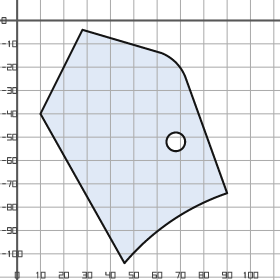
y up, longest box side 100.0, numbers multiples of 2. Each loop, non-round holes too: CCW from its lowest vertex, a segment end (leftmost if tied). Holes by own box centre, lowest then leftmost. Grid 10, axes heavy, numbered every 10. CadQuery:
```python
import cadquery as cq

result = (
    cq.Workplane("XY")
    .moveTo(46.0, -104.0)
    .threePointArc((66.0, -86.0), (90.0, -74.0))
    .lineTo(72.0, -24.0)
    .threePointArc((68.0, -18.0), (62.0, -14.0))
    .lineTo(28.0, -4.0)
    .lineTo(10.0, -40.0)
    .close()
    .moveTo(68.0, -52.0)
    .circle(4.0)
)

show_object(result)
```